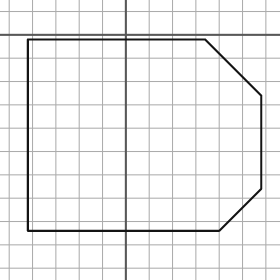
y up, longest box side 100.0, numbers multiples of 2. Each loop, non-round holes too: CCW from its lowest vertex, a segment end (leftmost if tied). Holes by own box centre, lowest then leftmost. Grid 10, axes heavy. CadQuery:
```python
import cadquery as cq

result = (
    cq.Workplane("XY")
    .moveTo(-42.0, -84.0)
    .lineTo(40.0, -84.0)
    .lineTo(58.0, -66.0)
    .lineTo(58.0, -26.0)
    .lineTo(34.0, -2.0)
    .lineTo(-42.0, -2.0)
    .close()
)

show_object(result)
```